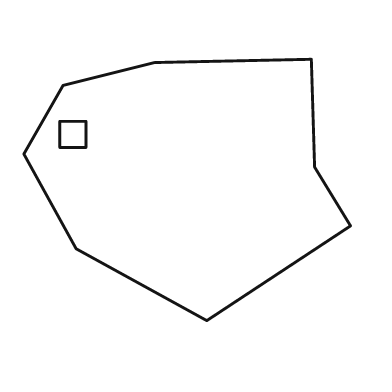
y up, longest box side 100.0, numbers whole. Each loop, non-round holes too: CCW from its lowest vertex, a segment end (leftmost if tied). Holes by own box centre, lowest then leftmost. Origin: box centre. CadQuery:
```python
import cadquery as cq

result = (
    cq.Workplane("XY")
    .moveTo(6.0, -40.0)
    .lineTo(50.0, -11.0)
    .lineTo(39.0, 7.0)
    .lineTo(38.0, 40.0)
    .lineTo(-10.0, 39.0)
    .lineTo(-38.0, 32.0)
    .lineTo(-50.0, 11.0)
    .lineTo(-34.0, -18.0)
    .close()
    .moveTo(-39.0, 13.0)
    .lineTo(-31.0, 13.0)
    .lineTo(-31.0, 21.0)
    .lineTo(-39.0, 21.0)
    .close()
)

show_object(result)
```